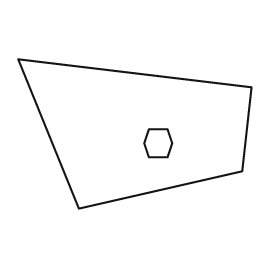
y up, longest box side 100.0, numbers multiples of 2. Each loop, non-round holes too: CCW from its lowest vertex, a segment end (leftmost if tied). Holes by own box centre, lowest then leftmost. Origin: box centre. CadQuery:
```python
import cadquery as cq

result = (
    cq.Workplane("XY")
    .moveTo(-24.0, -32.0)
    .lineTo(46.0, -16.0)
    .lineTo(50.0, 20.0)
    .lineTo(-50.0, 32.0)
    .close()
    .moveTo(6.0, -10.0)
    .lineTo(14.0, -10.0)
    .lineTo(16.0, -4.0)
    .lineTo(14.0, 2.0)
    .lineTo(6.0, 2.0)
    .lineTo(4.0, -4.0)
    .close()
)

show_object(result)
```